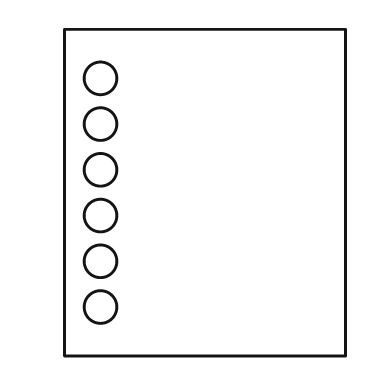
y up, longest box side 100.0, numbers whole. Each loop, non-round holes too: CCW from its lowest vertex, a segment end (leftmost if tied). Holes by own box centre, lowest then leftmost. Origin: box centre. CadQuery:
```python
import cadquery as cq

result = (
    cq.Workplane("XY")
    .moveTo(-43.0, -50.0)
    .lineTo(43.0, -50.0)
    .lineTo(43.0, 50.0)
    .lineTo(-43.0, 50.0)
    .close()
    .moveTo(-32.0, -35.0)
    .circle(5.0)
    .moveTo(-32.0, -21.0)
    .circle(5.0)
    .moveTo(-32.0, -7.0)
    .circle(5.0)
    .moveTo(-32.0, 7.0)
    .circle(5.0)
    .moveTo(-32.0, 21.0)
    .circle(5.0)
    .moveTo(-32.0, 35.0)
    .circle(5.0)
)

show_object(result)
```